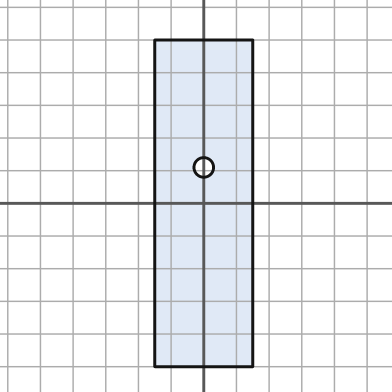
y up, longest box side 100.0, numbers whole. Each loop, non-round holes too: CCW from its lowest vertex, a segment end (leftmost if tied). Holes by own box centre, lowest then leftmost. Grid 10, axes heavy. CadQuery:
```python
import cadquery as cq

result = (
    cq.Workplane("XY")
    .moveTo(-15.0, -50.0)
    .lineTo(15.0, -50.0)
    .lineTo(15.0, 50.0)
    .lineTo(-15.0, 50.0)
    .close()
    .moveTo(0.0, 11.0)
    .circle(3.0)
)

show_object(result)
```